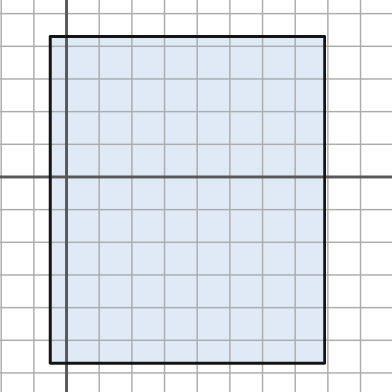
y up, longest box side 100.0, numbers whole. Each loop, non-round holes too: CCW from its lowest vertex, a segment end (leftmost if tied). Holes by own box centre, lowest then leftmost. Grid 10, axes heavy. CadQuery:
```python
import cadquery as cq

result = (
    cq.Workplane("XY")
    .moveTo(-5.0, -57.0)
    .lineTo(79.0, -57.0)
    .lineTo(79.0, 43.0)
    .lineTo(-5.0, 43.0)
    .close()
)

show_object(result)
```